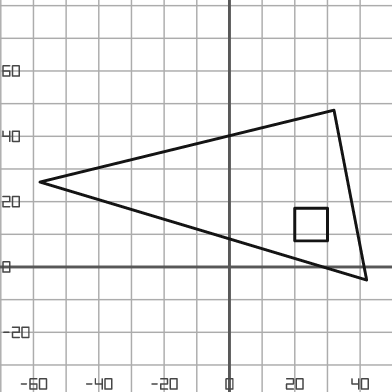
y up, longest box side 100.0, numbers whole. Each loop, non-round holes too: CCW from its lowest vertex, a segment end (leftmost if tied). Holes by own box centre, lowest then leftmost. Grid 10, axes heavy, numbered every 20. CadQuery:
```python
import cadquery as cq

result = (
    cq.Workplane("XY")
    .moveTo(42.0, -4.0)
    .lineTo(32.0, 48.0)
    .lineTo(-58.0, 26.0)
    .close()
    .moveTo(20.0, 8.0)
    .lineTo(30.0, 8.0)
    .lineTo(30.0, 18.0)
    .lineTo(20.0, 18.0)
    .close()
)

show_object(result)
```